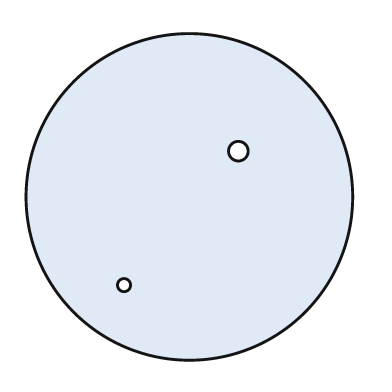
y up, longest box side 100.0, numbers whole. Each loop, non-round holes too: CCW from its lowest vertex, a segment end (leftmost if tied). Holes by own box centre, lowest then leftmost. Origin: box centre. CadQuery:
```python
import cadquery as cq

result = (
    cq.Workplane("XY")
    .moveTo(0.0, 0.0)
    .circle(50.0)
    .moveTo(-20.0, -27.0)
    .circle(2.0)
    .moveTo(15.0, 14.0)
    .circle(3.0)
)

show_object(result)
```